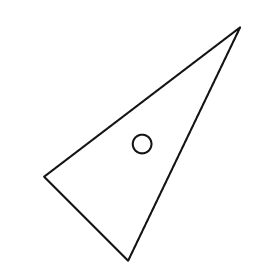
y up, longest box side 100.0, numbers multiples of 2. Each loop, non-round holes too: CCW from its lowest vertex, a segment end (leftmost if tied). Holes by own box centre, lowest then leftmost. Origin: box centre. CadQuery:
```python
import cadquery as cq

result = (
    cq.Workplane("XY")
    .moveTo(-6.0, -50.0)
    .lineTo(42.0, 50.0)
    .lineTo(-42.0, -14.0)
    .close()
    .moveTo(0.0, 0.0)
    .circle(4.0)
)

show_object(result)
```